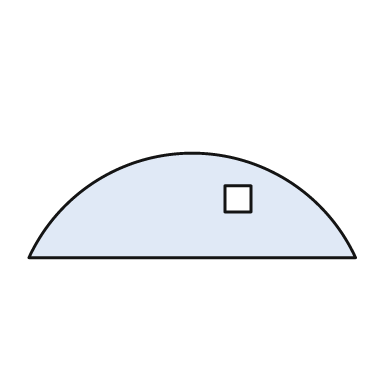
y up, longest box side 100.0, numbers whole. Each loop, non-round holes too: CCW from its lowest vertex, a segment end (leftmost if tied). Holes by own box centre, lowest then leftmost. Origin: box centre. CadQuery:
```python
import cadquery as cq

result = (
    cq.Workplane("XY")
    .moveTo(-50.0, -16.0)
    .lineTo(50.0, -16.0)
    .threePointArc((0.0, 16.0), (-50.0, -16.0))
    .close()
    .moveTo(10.0, -2.0)
    .lineTo(18.0, -2.0)
    .lineTo(18.0, 6.0)
    .lineTo(10.0, 6.0)
    .close()
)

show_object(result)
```